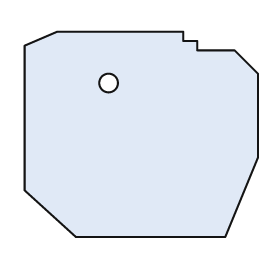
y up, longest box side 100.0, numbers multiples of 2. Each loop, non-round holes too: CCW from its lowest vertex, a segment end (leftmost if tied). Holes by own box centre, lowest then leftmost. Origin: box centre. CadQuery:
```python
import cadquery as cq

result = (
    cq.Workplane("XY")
    .moveTo(-28.0, -44.0)
    .lineTo(36.0, -44.0)
    .lineTo(50.0, -10.0)
    .lineTo(50.0, 26.0)
    .lineTo(40.0, 36.0)
    .lineTo(24.0, 36.0)
    .lineTo(24.0, 40.0)
    .lineTo(18.0, 40.0)
    .lineTo(18.0, 44.0)
    .lineTo(-36.0, 44.0)
    .lineTo(-50.0, 38.0)
    .lineTo(-50.0, -24.0)
    .close()
    .moveTo(-14.0, 22.0)
    .circle(4.0)
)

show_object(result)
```